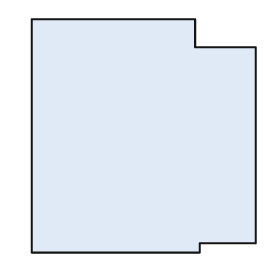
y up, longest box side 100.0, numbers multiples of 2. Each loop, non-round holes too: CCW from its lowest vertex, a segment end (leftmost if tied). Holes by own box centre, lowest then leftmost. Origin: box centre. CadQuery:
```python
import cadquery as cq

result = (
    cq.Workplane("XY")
    .moveTo(-48.0, -50.0)
    .lineTo(24.0, -50.0)
    .lineTo(24.0, -46.0)
    .lineTo(48.0, -46.0)
    .lineTo(48.0, 38.0)
    .lineTo(22.0, 38.0)
    .lineTo(22.0, 50.0)
    .lineTo(-48.0, 50.0)
    .close()
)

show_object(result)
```